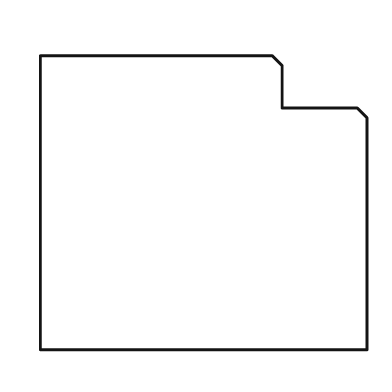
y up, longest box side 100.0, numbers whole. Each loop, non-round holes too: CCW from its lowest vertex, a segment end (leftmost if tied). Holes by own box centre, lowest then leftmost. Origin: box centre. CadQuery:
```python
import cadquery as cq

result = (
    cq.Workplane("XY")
    .moveTo(-50.0, -45.0)
    .lineTo(50.0, -45.0)
    .lineTo(50.0, 26.0)
    .lineTo(47.0, 29.0)
    .lineTo(24.0, 29.0)
    .lineTo(24.0, 42.0)
    .lineTo(21.0, 45.0)
    .lineTo(-50.0, 45.0)
    .close()
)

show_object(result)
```